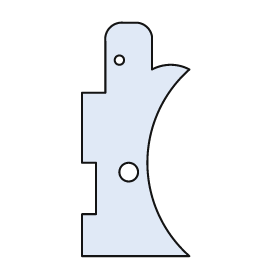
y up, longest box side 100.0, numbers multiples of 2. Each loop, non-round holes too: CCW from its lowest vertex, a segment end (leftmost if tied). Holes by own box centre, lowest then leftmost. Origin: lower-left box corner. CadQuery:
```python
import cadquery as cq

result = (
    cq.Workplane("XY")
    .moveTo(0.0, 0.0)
    .lineTo(46.0, 0.0)
    .threePointArc((28.0, 40.0), (46.0, 80.0))
    .threePointArc((38.0, 82.0), (30.0, 80.0))
    .lineTo(30.0, 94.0)
    .threePointArc((28.0, 98.0), (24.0, 100.0))
    .lineTo(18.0, 100.0)
    .threePointArc((12.0, 98.0), (10.0, 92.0))
    .lineTo(10.0, 70.0)
    .lineTo(0.0, 70.0)
    .lineTo(0.0, 40.0)
    .lineTo(6.0, 40.0)
    .lineTo(6.0, 18.0)
    .lineTo(0.0, 18.0)
    .close()
    .moveTo(20.0, 36.0)
    .circle(4.0)
    .moveTo(16.0, 84.0)
    .circle(2.0)
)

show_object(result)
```